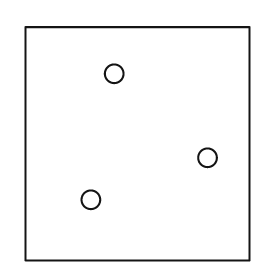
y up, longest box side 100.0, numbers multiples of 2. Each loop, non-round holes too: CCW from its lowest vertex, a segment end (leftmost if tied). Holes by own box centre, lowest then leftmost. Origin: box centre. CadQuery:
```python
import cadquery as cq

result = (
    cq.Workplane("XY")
    .moveTo(-48.0, -50.0)
    .lineTo(48.0, -50.0)
    .lineTo(48.0, 50.0)
    .lineTo(-48.0, 50.0)
    .close()
    .moveTo(-20.0, -24.0)
    .circle(4.0)
    .moveTo(30.0, -6.0)
    .circle(4.0)
    .moveTo(-10.0, 30.0)
    .circle(4.0)
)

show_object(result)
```